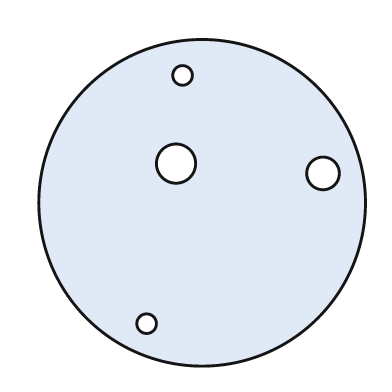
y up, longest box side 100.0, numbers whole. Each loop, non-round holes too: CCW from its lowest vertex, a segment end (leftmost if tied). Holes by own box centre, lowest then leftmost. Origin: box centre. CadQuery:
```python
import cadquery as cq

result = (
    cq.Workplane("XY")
    .moveTo(0.0, 0.0)
    .circle(50.0)
    .moveTo(-17.0, -37.0)
    .circle(3.0)
    .moveTo(37.0, 9.0)
    .circle(5.0)
    .moveTo(-8.0, 12.0)
    .circle(6.0)
    .moveTo(-6.0, 39.0)
    .circle(3.0)
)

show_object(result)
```